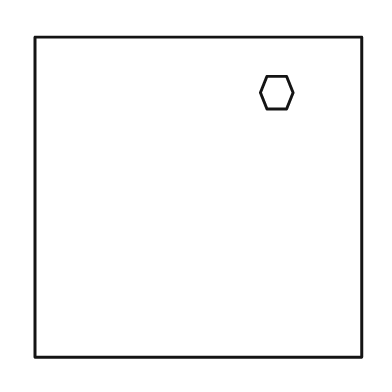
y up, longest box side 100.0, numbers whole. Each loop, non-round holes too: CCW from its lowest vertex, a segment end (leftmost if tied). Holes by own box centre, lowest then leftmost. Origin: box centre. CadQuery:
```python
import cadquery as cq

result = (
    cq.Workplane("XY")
    .moveTo(-50.0, -49.0)
    .lineTo(50.0, -49.0)
    .lineTo(50.0, 49.0)
    .lineTo(-50.0, 49.0)
    .close()
    .moveTo(21.0, 27.0)
    .lineTo(27.0, 27.0)
    .lineTo(29.0, 32.0)
    .lineTo(27.0, 37.0)
    .lineTo(21.0, 37.0)
    .lineTo(19.0, 32.0)
    .close()
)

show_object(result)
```